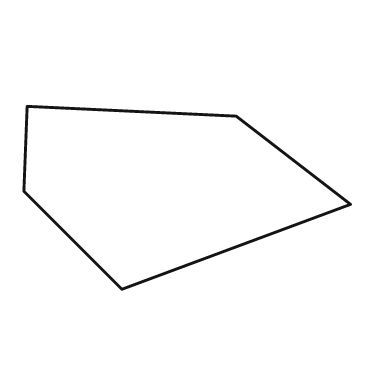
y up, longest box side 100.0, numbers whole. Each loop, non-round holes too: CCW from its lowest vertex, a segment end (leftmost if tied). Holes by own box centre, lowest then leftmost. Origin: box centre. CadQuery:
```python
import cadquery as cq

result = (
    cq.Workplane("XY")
    .moveTo(-20.0, -28.0)
    .lineTo(50.0, -2.0)
    .lineTo(15.0, 25.0)
    .lineTo(-49.0, 28.0)
    .lineTo(-50.0, 2.0)
    .close()
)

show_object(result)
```